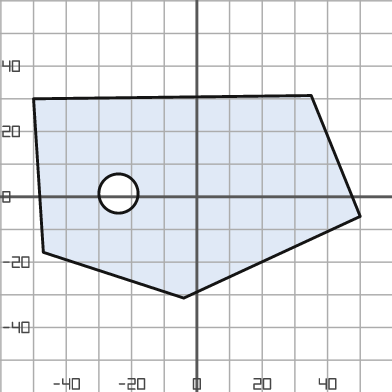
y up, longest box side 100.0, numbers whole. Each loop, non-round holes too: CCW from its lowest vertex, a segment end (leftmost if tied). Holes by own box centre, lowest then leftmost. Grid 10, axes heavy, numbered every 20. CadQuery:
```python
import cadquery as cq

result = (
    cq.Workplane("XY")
    .moveTo(-4.0, -31.0)
    .lineTo(50.0, -6.0)
    .lineTo(35.0, 31.0)
    .lineTo(-50.0, 30.0)
    .lineTo(-47.0, -17.0)
    .close()
    .moveTo(-24.0, 1.0)
    .circle(6.0)
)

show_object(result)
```